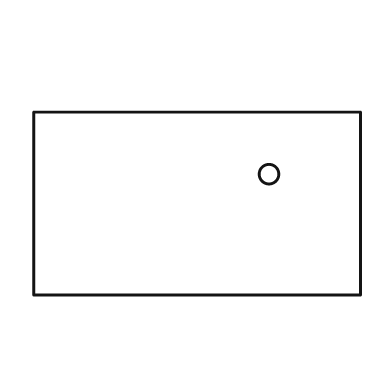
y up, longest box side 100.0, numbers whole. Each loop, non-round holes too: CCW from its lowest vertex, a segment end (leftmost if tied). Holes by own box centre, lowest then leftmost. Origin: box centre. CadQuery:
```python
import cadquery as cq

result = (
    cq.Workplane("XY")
    .moveTo(-50.0, -28.0)
    .lineTo(50.0, -28.0)
    .lineTo(50.0, 28.0)
    .lineTo(-50.0, 28.0)
    .close()
    .moveTo(22.0, 9.0)
    .circle(3.0)
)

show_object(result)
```